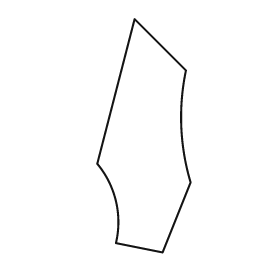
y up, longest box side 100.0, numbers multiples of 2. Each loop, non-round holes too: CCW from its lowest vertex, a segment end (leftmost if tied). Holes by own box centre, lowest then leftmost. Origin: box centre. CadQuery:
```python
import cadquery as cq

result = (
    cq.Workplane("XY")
    .moveTo(8.0, -50.0)
    .lineTo(20.0, -20.0)
    .threePointArc((16.0, 4.0), (18.0, 28.0))
    .lineTo(-4.0, 50.0)
    .lineTo(-20.0, -12.0)
    .threePointArc((-12.0, -28.0), (-12.0, -46.0))
    .close()
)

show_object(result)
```